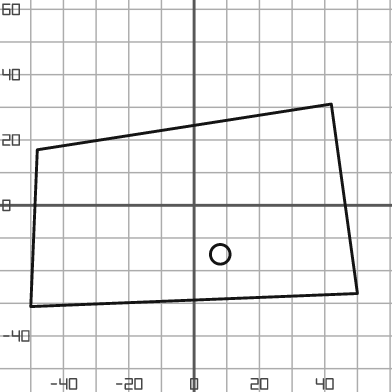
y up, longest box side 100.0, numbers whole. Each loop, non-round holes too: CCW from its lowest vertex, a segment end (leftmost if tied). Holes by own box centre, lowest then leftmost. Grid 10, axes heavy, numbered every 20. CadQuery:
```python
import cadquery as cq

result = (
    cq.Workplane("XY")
    .moveTo(-50.0, -31.0)
    .lineTo(50.0, -27.0)
    .lineTo(42.0, 31.0)
    .lineTo(-48.0, 17.0)
    .close()
    .moveTo(8.0, -15.0)
    .circle(3.0)
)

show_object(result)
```